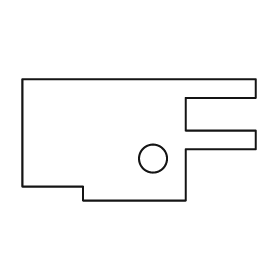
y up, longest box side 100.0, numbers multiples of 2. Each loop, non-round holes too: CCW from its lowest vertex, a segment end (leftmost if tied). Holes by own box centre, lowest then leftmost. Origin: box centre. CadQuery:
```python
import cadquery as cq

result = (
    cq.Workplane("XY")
    .moveTo(-24.0, -26.0)
    .lineTo(20.0, -26.0)
    .lineTo(20.0, -4.0)
    .lineTo(50.0, -4.0)
    .lineTo(50.0, 4.0)
    .lineTo(20.0, 4.0)
    .lineTo(20.0, 18.0)
    .lineTo(50.0, 18.0)
    .lineTo(50.0, 26.0)
    .lineTo(-50.0, 26.0)
    .lineTo(-50.0, -20.0)
    .lineTo(-24.0, -20.0)
    .close()
    .moveTo(6.0, -8.0)
    .circle(6.0)
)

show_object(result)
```